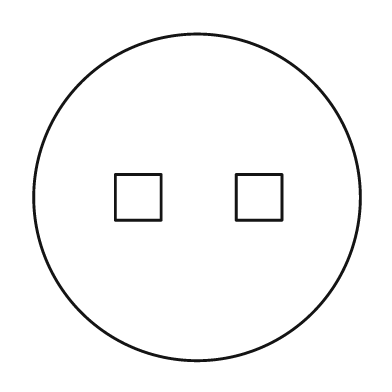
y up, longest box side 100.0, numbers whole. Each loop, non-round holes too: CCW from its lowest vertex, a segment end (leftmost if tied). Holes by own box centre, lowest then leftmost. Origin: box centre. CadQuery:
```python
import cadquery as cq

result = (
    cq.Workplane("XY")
    .moveTo(0.0, 0.0)
    .circle(50.0)
    .moveTo(-25.0, -7.0)
    .lineTo(-11.0, -7.0)
    .lineTo(-11.0, 7.0)
    .lineTo(-25.0, 7.0)
    .close()
    .moveTo(12.0, -7.0)
    .lineTo(26.0, -7.0)
    .lineTo(26.0, 7.0)
    .lineTo(12.0, 7.0)
    .close()
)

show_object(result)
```